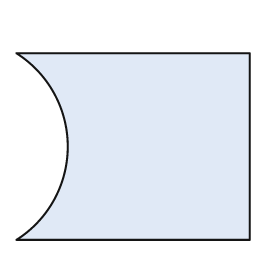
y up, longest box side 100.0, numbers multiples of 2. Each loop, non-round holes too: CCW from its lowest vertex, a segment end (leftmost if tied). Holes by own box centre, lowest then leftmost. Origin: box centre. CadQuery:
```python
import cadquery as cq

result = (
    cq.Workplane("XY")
    .moveTo(-50.0, -40.0)
    .lineTo(50.0, -40.0)
    .lineTo(50.0, 40.0)
    .lineTo(-50.0, 40.0)
    .threePointArc((-28.0, 0.0), (-50.0, -40.0))
    .close()
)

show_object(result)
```